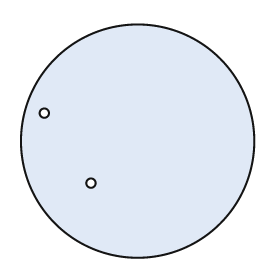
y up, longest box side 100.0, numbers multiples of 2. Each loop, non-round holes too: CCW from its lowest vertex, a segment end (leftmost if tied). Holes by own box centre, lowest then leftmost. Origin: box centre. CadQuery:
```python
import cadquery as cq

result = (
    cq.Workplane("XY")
    .moveTo(0.0, 0.0)
    .circle(50.0)
    .moveTo(-20.0, -18.0)
    .circle(2.0)
    .moveTo(-40.0, 12.0)
    .circle(2.0)
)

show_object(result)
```